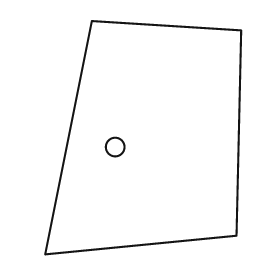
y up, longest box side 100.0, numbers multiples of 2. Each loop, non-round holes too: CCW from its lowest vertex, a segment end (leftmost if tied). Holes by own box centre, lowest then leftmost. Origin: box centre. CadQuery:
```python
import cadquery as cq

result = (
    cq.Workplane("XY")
    .moveTo(-42.0, -50.0)
    .lineTo(40.0, -42.0)
    .lineTo(42.0, 46.0)
    .lineTo(-22.0, 50.0)
    .close()
    .moveTo(-12.0, -4.0)
    .circle(4.0)
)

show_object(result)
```